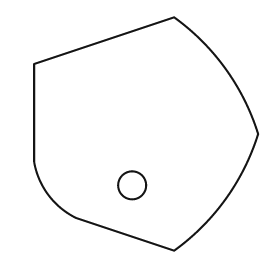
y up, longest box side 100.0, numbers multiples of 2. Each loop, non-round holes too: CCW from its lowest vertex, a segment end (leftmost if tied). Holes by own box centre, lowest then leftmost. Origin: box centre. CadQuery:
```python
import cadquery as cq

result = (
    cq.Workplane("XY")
    .moveTo(12.0, -50.0)
    .threePointArc((34.0, -28.0), (48.0, 0.0))
    .threePointArc((34.0, 28.0), (12.0, 50.0))
    .lineTo(-48.0, 30.0)
    .lineTo(-48.0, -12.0)
    .threePointArc((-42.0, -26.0), (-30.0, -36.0))
    .close()
    .moveTo(-6.0, -22.0)
    .circle(6.0)
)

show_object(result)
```